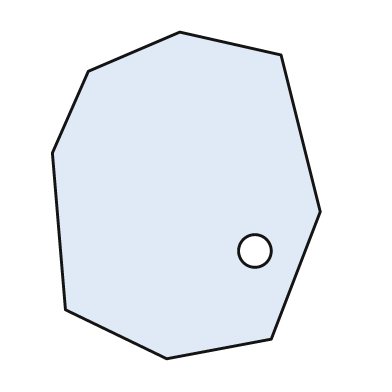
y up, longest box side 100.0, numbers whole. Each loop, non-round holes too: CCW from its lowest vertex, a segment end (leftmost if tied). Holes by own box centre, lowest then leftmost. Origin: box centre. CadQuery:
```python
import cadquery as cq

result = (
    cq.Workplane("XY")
    .moveTo(-6.0, -50.0)
    .lineTo(26.0, -44.0)
    .lineTo(41.0, -5.0)
    .lineTo(29.0, 43.0)
    .lineTo(-2.0, 50.0)
    .lineTo(-30.0, 38.0)
    .lineTo(-41.0, 13.0)
    .lineTo(-37.0, -35.0)
    .close()
    .moveTo(21.0, -17.0)
    .circle(5.0)
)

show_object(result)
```